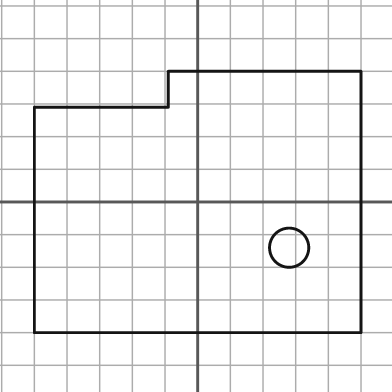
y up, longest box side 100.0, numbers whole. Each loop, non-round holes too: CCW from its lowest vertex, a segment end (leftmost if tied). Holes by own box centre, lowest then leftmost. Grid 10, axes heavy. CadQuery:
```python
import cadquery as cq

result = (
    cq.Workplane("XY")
    .moveTo(-50.0, -40.0)
    .lineTo(50.0, -40.0)
    .lineTo(50.0, 40.0)
    .lineTo(-9.0, 40.0)
    .lineTo(-9.0, 29.0)
    .lineTo(-50.0, 29.0)
    .close()
    .moveTo(28.0, -14.0)
    .circle(6.0)
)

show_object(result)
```